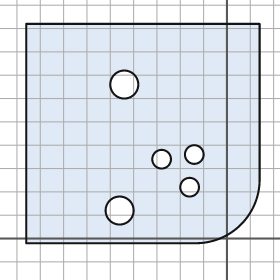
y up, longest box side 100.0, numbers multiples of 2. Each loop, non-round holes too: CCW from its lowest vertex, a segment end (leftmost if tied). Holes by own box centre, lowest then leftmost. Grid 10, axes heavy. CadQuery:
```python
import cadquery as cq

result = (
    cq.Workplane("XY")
    .moveTo(-86.0, -2.0)
    .lineTo(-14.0, -2.0)
    .threePointArc((6.0, 6.0), (14.0, 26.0))
    .lineTo(14.0, 92.0)
    .lineTo(-86.0, 92.0)
    .close()
    .moveTo(-46.0, 12.0)
    .circle(6.0)
    .moveTo(-16.0, 22.0)
    .circle(4.0)
    .moveTo(-28.0, 34.0)
    .circle(4.0)
    .moveTo(-14.0, 36.0)
    .circle(4.0)
    .moveTo(-44.0, 66.0)
    .circle(6.0)
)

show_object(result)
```